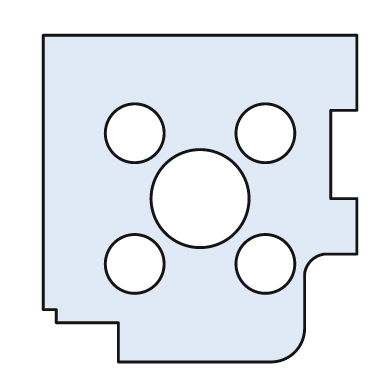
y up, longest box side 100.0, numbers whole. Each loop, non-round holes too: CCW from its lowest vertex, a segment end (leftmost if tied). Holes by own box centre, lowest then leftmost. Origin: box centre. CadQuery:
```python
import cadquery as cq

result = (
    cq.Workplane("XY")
    .moveTo(-25.0, -50.0)
    .lineTo(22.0, -50.0)
    .threePointArc((29.0, -47.0), (32.0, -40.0))
    .lineTo(32.0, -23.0)
    .threePointArc((34.0, -19.0), (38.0, -17.0))
    .lineTo(48.0, -17.0)
    .lineTo(48.0, 0.0)
    .lineTo(40.0, 0.0)
    .lineTo(40.0, 27.0)
    .lineTo(48.0, 27.0)
    .lineTo(48.0, 50.0)
    .lineTo(-48.0, 50.0)
    .lineTo(-48.0, -34.0)
    .lineTo(-44.0, -34.0)
    .lineTo(-44.0, -38.0)
    .lineTo(-25.0, -38.0)
    .close()
    .moveTo(-20.0, -20.0)
    .circle(9.0)
    .moveTo(20.0, -20.0)
    .circle(9.0)
    .moveTo(0.0, 0.0)
    .circle(15.0)
    .moveTo(-20.0, 20.0)
    .circle(9.0)
    .moveTo(20.0, 20.0)
    .circle(9.0)
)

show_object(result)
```